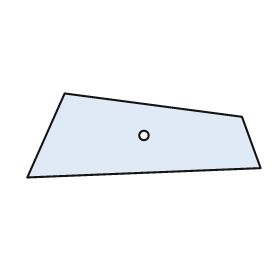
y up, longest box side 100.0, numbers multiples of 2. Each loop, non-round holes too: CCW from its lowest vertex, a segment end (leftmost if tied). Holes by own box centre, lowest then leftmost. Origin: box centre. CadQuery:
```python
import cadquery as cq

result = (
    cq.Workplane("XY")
    .moveTo(-50.0, -18.0)
    .lineTo(50.0, -14.0)
    .lineTo(42.0, 8.0)
    .lineTo(-34.0, 18.0)
    .close()
    .moveTo(0.0, 0.0)
    .circle(2.0)
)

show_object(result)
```